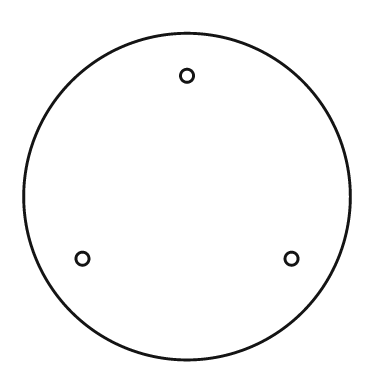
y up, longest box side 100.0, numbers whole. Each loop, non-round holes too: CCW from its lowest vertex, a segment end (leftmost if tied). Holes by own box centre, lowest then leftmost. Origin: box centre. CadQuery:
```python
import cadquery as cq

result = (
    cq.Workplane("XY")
    .moveTo(0.0, 0.0)
    .circle(50.0)
    .moveTo(-32.0, -19.0)
    .circle(2.0)
    .moveTo(32.0, -19.0)
    .circle(2.0)
    .moveTo(0.0, 37.0)
    .circle(2.0)
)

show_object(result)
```